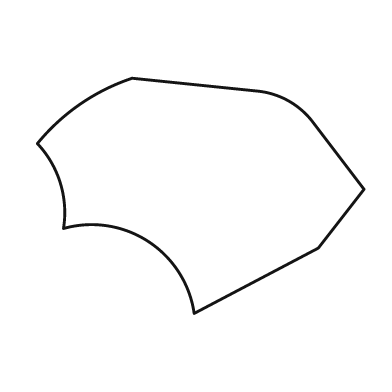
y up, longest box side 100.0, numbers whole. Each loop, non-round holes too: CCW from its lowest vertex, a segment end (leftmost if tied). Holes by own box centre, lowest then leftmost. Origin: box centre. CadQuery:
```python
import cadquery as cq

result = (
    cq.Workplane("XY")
    .moveTo(-2.0, -36.0)
    .lineTo(36.0, -16.0)
    .lineTo(50.0, 2.0)
    .lineTo(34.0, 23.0)
    .threePointArc((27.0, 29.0), (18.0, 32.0))
    .lineTo(-21.0, 36.0)
    .threePointArc((-37.0, 28.0), (-50.0, 16.0))
    .threePointArc((-43.0, 4.0), (-42.0, -10.0))
    .threePointArc((-16.0, -14.0), (-2.0, -36.0))
    .close()
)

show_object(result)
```